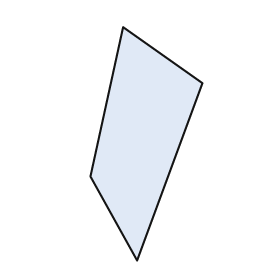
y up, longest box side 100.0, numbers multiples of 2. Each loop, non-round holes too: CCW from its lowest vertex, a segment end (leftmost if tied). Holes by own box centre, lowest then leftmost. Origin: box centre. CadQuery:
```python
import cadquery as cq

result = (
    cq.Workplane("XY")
    .moveTo(-4.0, -50.0)
    .lineTo(24.0, 26.0)
    .lineTo(-10.0, 50.0)
    .lineTo(-24.0, -14.0)
    .close()
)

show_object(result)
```